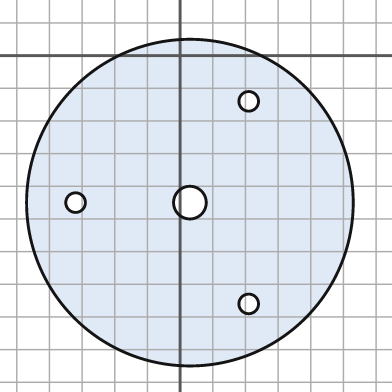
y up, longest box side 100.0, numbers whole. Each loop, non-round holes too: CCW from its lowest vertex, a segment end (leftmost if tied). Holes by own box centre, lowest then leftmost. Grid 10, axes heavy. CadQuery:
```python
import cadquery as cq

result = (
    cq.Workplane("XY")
    .moveTo(3.0, -45.0)
    .circle(50.0)
    .moveTo(21.0, -76.0)
    .circle(3.0)
    .moveTo(-32.0, -45.0)
    .circle(3.0)
    .moveTo(3.0, -45.0)
    .circle(5.0)
    .moveTo(21.0, -14.0)
    .circle(3.0)
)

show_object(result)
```